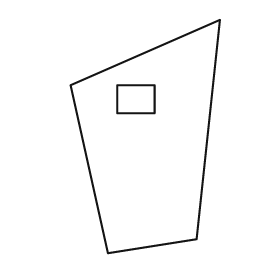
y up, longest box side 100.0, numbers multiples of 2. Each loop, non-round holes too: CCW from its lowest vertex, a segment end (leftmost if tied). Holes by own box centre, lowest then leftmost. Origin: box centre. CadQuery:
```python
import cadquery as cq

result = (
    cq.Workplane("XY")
    .moveTo(-16.0, -50.0)
    .lineTo(22.0, -44.0)
    .lineTo(32.0, 50.0)
    .lineTo(-32.0, 22.0)
    .close()
    .moveTo(-12.0, 10.0)
    .lineTo(4.0, 10.0)
    .lineTo(4.0, 22.0)
    .lineTo(-12.0, 22.0)
    .close()
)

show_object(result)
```